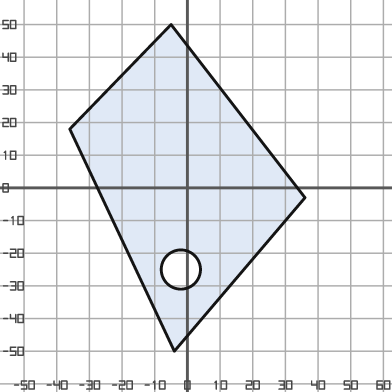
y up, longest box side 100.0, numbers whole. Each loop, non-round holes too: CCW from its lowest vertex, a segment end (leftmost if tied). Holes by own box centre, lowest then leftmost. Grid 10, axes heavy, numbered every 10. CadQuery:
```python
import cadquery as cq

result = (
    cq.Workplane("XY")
    .moveTo(-4.0, -50.0)
    .lineTo(36.0, -3.0)
    .lineTo(-5.0, 50.0)
    .lineTo(-36.0, 18.0)
    .close()
    .moveTo(-2.0, -25.0)
    .circle(6.0)
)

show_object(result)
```